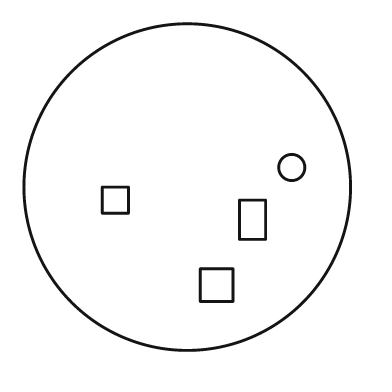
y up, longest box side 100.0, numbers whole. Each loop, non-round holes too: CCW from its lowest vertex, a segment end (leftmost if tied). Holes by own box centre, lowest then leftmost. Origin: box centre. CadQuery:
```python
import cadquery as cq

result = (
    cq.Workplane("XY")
    .moveTo(0.0, 0.0)
    .circle(50.0)
    .moveTo(4.0, -35.0)
    .lineTo(14.0, -35.0)
    .lineTo(14.0, -25.0)
    .lineTo(4.0, -25.0)
    .close()
    .moveTo(16.0, -16.0)
    .lineTo(24.0, -16.0)
    .lineTo(24.0, -4.0)
    .lineTo(16.0, -4.0)
    .close()
    .moveTo(-26.0, -8.0)
    .lineTo(-18.0, -8.0)
    .lineTo(-18.0, 0.0)
    .lineTo(-26.0, 0.0)
    .close()
    .moveTo(32.0, 6.0)
    .circle(4.0)
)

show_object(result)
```